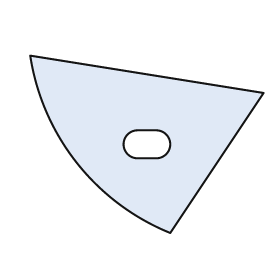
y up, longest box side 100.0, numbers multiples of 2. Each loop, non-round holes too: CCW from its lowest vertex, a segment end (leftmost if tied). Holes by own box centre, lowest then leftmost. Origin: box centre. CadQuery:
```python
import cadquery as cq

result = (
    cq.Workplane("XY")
    .moveTo(10.0, -38.0)
    .lineTo(50.0, 22.0)
    .lineTo(-50.0, 38.0)
    .threePointArc((-30.0, -8.0), (10.0, -38.0))
    .close()
    .moveTo(-4.0, -6.0)
    .lineTo(4.0, -6.0)
    .threePointArc((10.0, 0.0), (4.0, 6.0))
    .lineTo(-4.0, 6.0)
    .threePointArc((-10.0, 0.0), (-4.0, -6.0))
    .close()
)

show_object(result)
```